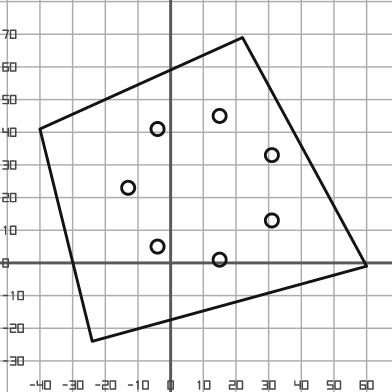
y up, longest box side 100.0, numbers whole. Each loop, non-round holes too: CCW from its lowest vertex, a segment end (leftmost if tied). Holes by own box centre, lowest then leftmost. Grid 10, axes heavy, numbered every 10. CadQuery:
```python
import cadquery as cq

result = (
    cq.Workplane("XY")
    .moveTo(-24.0, -24.0)
    .lineTo(60.0, -1.0)
    .lineTo(22.0, 69.0)
    .lineTo(-40.0, 41.0)
    .close()
    .moveTo(15.0, 1.0)
    .circle(2.0)
    .moveTo(-4.0, 5.0)
    .circle(2.0)
    .moveTo(31.0, 13.0)
    .circle(2.0)
    .moveTo(-13.0, 23.0)
    .circle(2.0)
    .moveTo(31.0, 33.0)
    .circle(2.0)
    .moveTo(-4.0, 41.0)
    .circle(2.0)
    .moveTo(15.0, 45.0)
    .circle(2.0)
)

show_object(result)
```